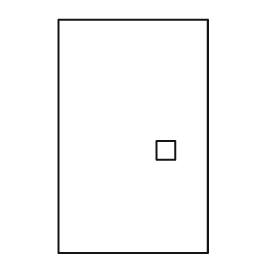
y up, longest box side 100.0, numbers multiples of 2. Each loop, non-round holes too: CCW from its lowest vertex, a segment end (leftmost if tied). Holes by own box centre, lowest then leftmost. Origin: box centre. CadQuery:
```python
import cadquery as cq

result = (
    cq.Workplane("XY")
    .moveTo(-32.0, -50.0)
    .lineTo(32.0, -50.0)
    .lineTo(32.0, 50.0)
    .lineTo(-32.0, 50.0)
    .close()
    .moveTo(10.0, -10.0)
    .lineTo(18.0, -10.0)
    .lineTo(18.0, -2.0)
    .lineTo(10.0, -2.0)
    .close()
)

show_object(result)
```